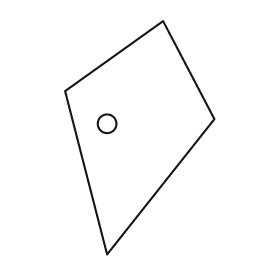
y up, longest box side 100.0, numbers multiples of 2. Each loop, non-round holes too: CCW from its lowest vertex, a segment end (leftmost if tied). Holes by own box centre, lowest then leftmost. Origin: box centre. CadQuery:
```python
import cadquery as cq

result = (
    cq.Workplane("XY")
    .moveTo(-14.0, -50.0)
    .lineTo(32.0, 8.0)
    .lineTo(10.0, 50.0)
    .lineTo(-32.0, 20.0)
    .close()
    .moveTo(-14.0, 6.0)
    .circle(4.0)
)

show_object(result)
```